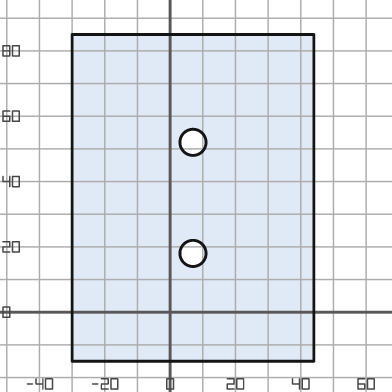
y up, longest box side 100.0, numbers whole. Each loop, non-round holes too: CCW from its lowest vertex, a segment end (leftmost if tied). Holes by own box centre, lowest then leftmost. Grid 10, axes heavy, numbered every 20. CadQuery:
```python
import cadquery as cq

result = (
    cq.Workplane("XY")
    .moveTo(-30.0, -15.0)
    .lineTo(44.0, -15.0)
    .lineTo(44.0, 85.0)
    .lineTo(-30.0, 85.0)
    .close()
    .moveTo(7.0, 18.0)
    .circle(4.0)
    .moveTo(7.0, 52.0)
    .circle(4.0)
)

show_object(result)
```